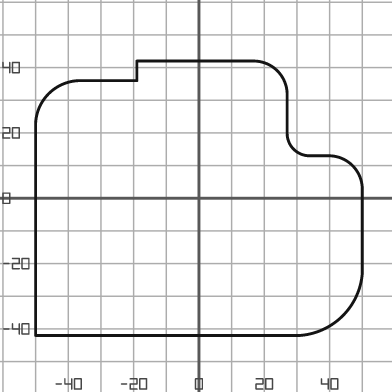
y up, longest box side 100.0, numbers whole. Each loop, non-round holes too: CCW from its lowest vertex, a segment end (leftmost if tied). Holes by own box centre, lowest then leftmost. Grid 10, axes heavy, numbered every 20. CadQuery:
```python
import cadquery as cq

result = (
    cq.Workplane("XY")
    .moveTo(-50.0, -42.0)
    .lineTo(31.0, -42.0)
    .threePointArc((44.0, -36.0), (50.0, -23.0))
    .lineTo(50.0, 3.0)
    .threePointArc((47.0, 10.0), (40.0, 13.0))
    .lineTo(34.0, 13.0)
    .threePointArc((29.0, 15.0), (27.0, 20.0))
    .lineTo(27.0, 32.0)
    .threePointArc((24.0, 39.0), (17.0, 42.0))
    .lineTo(-19.0, 42.0)
    .lineTo(-19.0, 36.0)
    .lineTo(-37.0, 36.0)
    .threePointArc((-46.0, 32.0), (-50.0, 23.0))
    .close()
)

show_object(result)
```